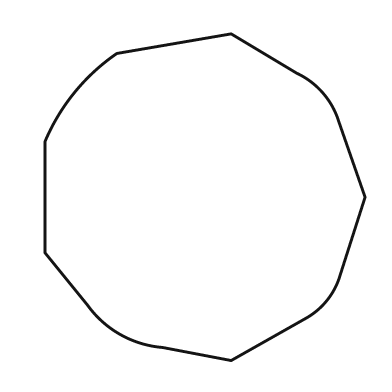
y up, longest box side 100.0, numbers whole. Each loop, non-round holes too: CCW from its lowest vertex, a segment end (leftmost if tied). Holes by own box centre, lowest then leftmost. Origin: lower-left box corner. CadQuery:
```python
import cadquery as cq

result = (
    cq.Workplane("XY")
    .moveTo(57.0, 0.0)
    .lineTo(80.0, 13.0)
    .threePointArc((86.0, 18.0), (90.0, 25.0))
    .lineTo(98.0, 50.0)
    .lineTo(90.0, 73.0)
    .threePointArc((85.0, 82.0), (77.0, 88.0))
    .lineTo(57.0, 100.0)
    .lineTo(22.0, 94.0)
    .threePointArc((9.0, 82.0), (0.0, 67.0))
    .lineTo(0.0, 33.0)
    .lineTo(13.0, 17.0)
    .threePointArc((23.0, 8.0), (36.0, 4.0))
    .close()
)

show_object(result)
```